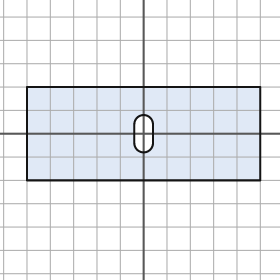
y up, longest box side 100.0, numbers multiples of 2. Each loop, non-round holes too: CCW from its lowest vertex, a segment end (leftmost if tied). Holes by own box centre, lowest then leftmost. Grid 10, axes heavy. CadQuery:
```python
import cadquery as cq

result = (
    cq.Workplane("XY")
    .moveTo(-50.0, -20.0)
    .lineTo(50.0, -20.0)
    .lineTo(50.0, 20.0)
    .lineTo(-50.0, 20.0)
    .close()
    .moveTo(-4.0, -4.0)
    .threePointArc((0.0, -8.0), (4.0, -4.0))
    .lineTo(4.0, 4.0)
    .threePointArc((0.0, 8.0), (-4.0, 4.0))
    .close()
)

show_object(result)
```